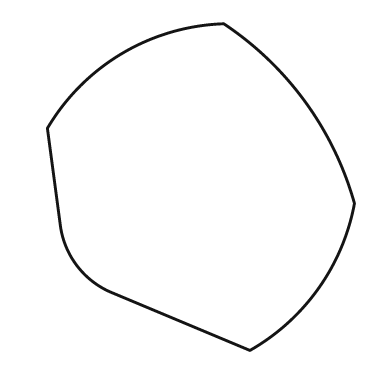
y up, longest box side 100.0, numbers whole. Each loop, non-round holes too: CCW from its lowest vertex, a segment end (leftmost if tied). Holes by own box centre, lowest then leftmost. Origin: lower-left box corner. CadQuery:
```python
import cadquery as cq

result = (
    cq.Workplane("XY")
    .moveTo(62.0, 0.0)
    .threePointArc((83.0, 19.0), (94.0, 45.0))
    .threePointArc((79.0, 76.0), (54.0, 100.0))
    .threePointArc((23.0, 91.0), (0.0, 68.0))
    .lineTo(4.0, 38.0)
    .threePointArc((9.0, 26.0), (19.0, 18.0))
    .close()
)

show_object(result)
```